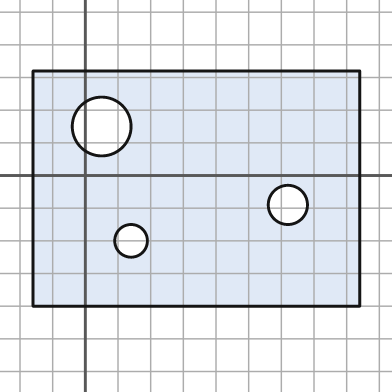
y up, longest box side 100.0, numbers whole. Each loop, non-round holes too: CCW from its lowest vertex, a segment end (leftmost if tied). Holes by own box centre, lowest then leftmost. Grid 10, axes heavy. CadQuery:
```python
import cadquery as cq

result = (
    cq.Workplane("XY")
    .moveTo(-16.0, -40.0)
    .lineTo(84.0, -40.0)
    .lineTo(84.0, 32.0)
    .lineTo(-16.0, 32.0)
    .close()
    .moveTo(14.0, -20.0)
    .circle(5.0)
    .moveTo(62.0, -9.0)
    .circle(6.0)
    .moveTo(5.0, 15.0)
    .circle(9.0)
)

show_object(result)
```